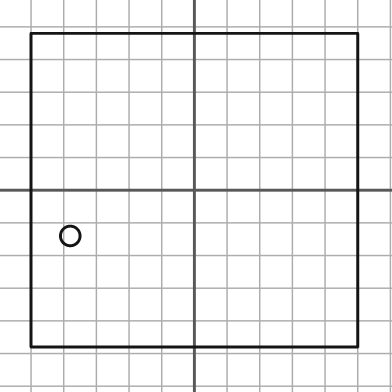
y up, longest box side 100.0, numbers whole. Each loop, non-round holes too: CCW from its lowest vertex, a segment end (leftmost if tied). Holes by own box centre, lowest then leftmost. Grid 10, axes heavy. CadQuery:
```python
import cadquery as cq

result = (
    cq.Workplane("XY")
    .moveTo(-50.0, -48.0)
    .lineTo(50.0, -48.0)
    .lineTo(50.0, 48.0)
    .lineTo(-50.0, 48.0)
    .close()
    .moveTo(-38.0, -14.0)
    .circle(3.0)
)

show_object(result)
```